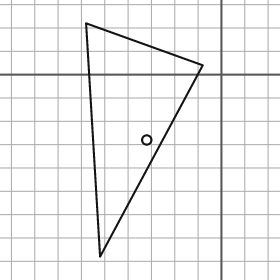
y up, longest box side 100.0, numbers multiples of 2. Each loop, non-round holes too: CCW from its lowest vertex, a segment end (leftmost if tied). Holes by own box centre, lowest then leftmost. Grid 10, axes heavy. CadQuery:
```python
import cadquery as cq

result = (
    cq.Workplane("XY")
    .moveTo(-52.0, -78.0)
    .lineTo(-8.0, 4.0)
    .lineTo(-58.0, 22.0)
    .close()
    .moveTo(-32.0, -28.0)
    .circle(2.0)
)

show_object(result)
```